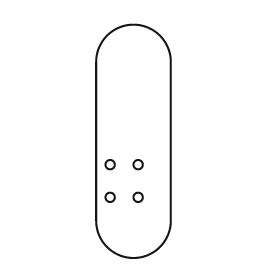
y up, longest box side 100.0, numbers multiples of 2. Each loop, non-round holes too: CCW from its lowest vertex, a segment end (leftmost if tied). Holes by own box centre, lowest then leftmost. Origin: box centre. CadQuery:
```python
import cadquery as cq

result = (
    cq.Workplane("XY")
    .moveTo(-16.0, -34.0)
    .threePointArc((0.0, -50.0), (16.0, -34.0))
    .lineTo(16.0, 34.0)
    .threePointArc((0.0, 50.0), (-16.0, 34.0))
    .close()
    .moveTo(-10.0, -24.0)
    .circle(2.0)
    .moveTo(2.0, -24.0)
    .circle(2.0)
    .moveTo(-10.0, -10.0)
    .circle(2.0)
    .moveTo(2.0, -10.0)
    .circle(2.0)
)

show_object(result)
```